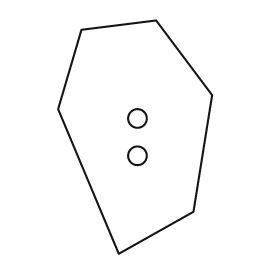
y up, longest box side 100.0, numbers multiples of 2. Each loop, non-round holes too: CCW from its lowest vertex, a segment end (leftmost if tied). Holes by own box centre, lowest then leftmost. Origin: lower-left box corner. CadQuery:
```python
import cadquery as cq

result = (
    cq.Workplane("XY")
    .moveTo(26.0, 0.0)
    .lineTo(58.0, 18.0)
    .lineTo(66.0, 68.0)
    .lineTo(42.0, 100.0)
    .lineTo(10.0, 96.0)
    .lineTo(0.0, 62.0)
    .close()
    .moveTo(34.0, 42.0)
    .circle(4.0)
    .moveTo(34.0, 58.0)
    .circle(4.0)
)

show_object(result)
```